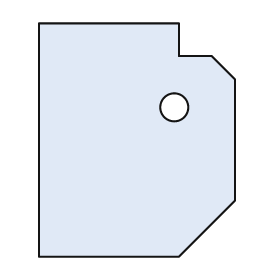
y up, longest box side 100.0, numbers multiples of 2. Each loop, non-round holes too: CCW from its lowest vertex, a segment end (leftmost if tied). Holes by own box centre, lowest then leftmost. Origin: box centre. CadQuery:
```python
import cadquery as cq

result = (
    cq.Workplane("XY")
    .moveTo(-42.0, -50.0)
    .lineTo(18.0, -50.0)
    .lineTo(42.0, -26.0)
    .lineTo(42.0, 26.0)
    .lineTo(32.0, 36.0)
    .lineTo(18.0, 36.0)
    .lineTo(18.0, 50.0)
    .lineTo(-42.0, 50.0)
    .close()
    .moveTo(16.0, 14.0)
    .circle(6.0)
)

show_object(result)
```